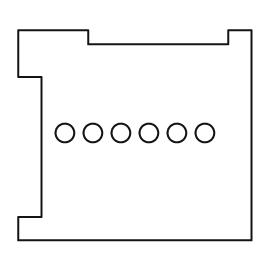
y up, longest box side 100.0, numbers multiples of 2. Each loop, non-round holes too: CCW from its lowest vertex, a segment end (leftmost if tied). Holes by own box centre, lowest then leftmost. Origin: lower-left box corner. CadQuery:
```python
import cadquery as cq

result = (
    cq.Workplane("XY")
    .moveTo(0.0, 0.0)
    .lineTo(100.0, 0.0)
    .lineTo(100.0, 90.0)
    .lineTo(90.0, 90.0)
    .lineTo(90.0, 84.0)
    .lineTo(30.0, 84.0)
    .lineTo(30.0, 90.0)
    .lineTo(0.0, 90.0)
    .lineTo(0.0, 70.0)
    .lineTo(10.0, 70.0)
    .lineTo(10.0, 10.0)
    .lineTo(0.0, 10.0)
    .close()
    .moveTo(20.0, 46.0)
    .circle(4.0)
    .moveTo(32.0, 46.0)
    .circle(4.0)
    .moveTo(44.0, 46.0)
    .circle(4.0)
    .moveTo(56.0, 46.0)
    .circle(4.0)
    .moveTo(68.0, 46.0)
    .circle(4.0)
    .moveTo(80.0, 46.0)
    .circle(4.0)
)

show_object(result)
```